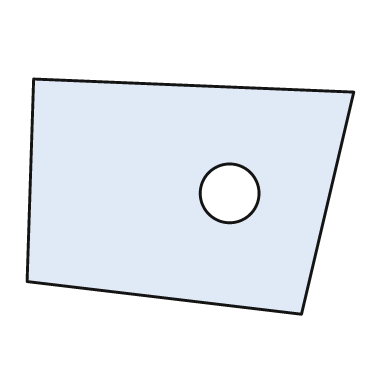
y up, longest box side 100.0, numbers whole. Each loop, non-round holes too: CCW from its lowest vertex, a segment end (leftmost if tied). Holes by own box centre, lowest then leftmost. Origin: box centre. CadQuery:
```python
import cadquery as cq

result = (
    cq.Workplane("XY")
    .moveTo(34.0, -36.0)
    .lineTo(50.0, 32.0)
    .lineTo(-48.0, 36.0)
    .lineTo(-50.0, -26.0)
    .close()
    .moveTo(12.0, 1.0)
    .circle(9.0)
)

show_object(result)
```